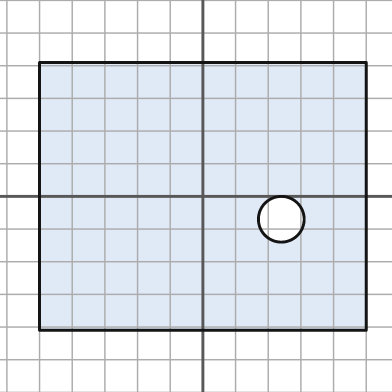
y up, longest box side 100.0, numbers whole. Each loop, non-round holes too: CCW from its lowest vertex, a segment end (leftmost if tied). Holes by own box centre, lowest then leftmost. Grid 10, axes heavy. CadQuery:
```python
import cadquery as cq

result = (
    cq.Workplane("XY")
    .moveTo(-50.0, -41.0)
    .lineTo(50.0, -41.0)
    .lineTo(50.0, 41.0)
    .lineTo(-50.0, 41.0)
    .close()
    .moveTo(24.0, -7.0)
    .circle(7.0)
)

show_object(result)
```